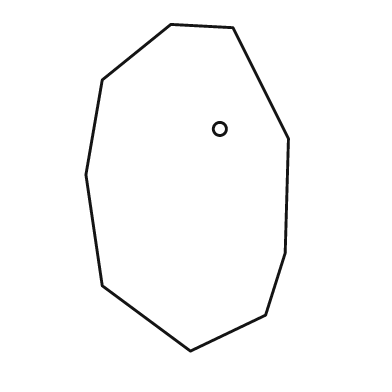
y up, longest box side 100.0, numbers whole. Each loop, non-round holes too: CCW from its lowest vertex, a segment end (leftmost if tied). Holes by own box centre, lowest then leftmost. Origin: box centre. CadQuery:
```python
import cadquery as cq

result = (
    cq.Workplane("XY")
    .moveTo(1.0, -50.0)
    .lineTo(24.0, -39.0)
    .lineTo(30.0, -20.0)
    .lineTo(31.0, 15.0)
    .lineTo(14.0, 49.0)
    .lineTo(-5.0, 50.0)
    .lineTo(-26.0, 33.0)
    .lineTo(-31.0, 4.0)
    .lineTo(-26.0, -30.0)
    .close()
    .moveTo(10.0, 18.0)
    .circle(2.0)
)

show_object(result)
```